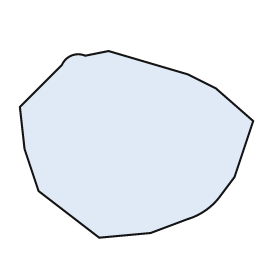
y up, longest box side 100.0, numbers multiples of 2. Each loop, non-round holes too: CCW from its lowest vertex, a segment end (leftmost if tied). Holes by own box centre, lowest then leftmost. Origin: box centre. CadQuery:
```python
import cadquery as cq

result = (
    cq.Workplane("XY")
    .moveTo(-16.0, -40.0)
    .lineTo(6.0, -38.0)
    .lineTo(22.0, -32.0)
    .threePointArc((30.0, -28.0), (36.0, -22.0))
    .lineTo(42.0, -14.0)
    .lineTo(50.0, 10.0)
    .lineTo(34.0, 24.0)
    .lineTo(22.0, 30.0)
    .lineTo(-12.0, 40.0)
    .lineTo(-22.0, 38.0)
    .threePointArc((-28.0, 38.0), (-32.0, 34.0))
    .lineTo(-50.0, 16.0)
    .lineTo(-48.0, -2.0)
    .lineTo(-42.0, -20.0)
    .close()
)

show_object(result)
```